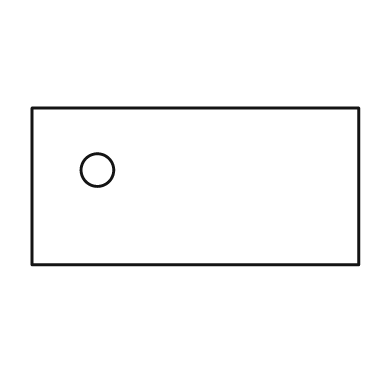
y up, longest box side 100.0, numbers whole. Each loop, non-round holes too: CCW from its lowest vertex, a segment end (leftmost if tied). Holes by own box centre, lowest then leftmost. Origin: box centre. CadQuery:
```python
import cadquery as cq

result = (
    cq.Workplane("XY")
    .moveTo(-50.0, -24.0)
    .lineTo(50.0, -24.0)
    .lineTo(50.0, 24.0)
    .lineTo(-50.0, 24.0)
    .close()
    .moveTo(-30.0, 5.0)
    .circle(5.0)
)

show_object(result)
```